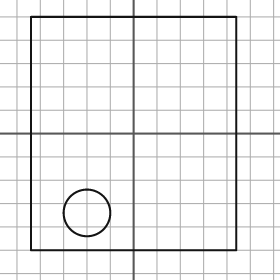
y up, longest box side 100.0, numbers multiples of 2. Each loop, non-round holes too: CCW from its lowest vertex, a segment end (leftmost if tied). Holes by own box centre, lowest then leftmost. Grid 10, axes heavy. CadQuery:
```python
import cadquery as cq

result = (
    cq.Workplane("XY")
    .moveTo(-44.0, -50.0)
    .lineTo(44.0, -50.0)
    .lineTo(44.0, 50.0)
    .lineTo(-44.0, 50.0)
    .close()
    .moveTo(-20.0, -34.0)
    .circle(10.0)
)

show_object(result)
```